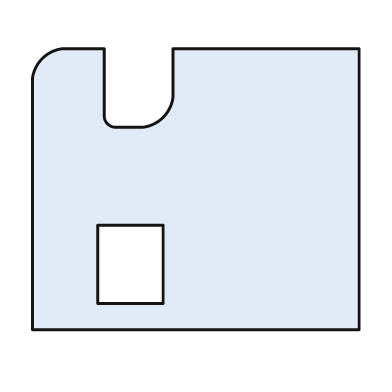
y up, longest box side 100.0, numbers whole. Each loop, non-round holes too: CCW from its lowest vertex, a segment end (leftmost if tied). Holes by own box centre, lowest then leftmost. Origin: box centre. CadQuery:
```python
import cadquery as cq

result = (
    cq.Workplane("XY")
    .moveTo(-50.0, -43.0)
    .lineTo(50.0, -43.0)
    .lineTo(50.0, 43.0)
    .lineTo(-7.0, 43.0)
    .lineTo(-7.0, 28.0)
    .threePointArc((-10.0, 22.0), (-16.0, 19.0))
    .lineTo(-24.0, 19.0)
    .threePointArc((-27.0, 20.0), (-28.0, 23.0))
    .lineTo(-28.0, 43.0)
    .lineTo(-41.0, 43.0)
    .threePointArc((-47.0, 40.0), (-50.0, 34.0))
    .close()
    .moveTo(-30.0, -35.0)
    .lineTo(-10.0, -35.0)
    .lineTo(-10.0, -11.0)
    .lineTo(-30.0, -11.0)
    .close()
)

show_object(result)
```